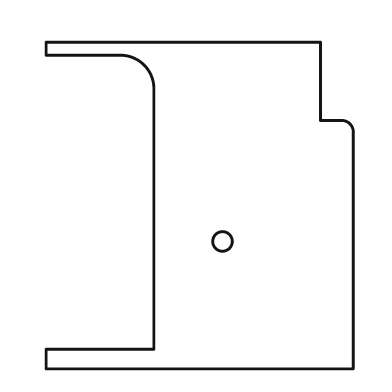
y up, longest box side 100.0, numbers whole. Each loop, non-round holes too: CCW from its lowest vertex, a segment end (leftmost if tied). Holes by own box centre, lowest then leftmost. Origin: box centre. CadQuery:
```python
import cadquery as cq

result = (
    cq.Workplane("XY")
    .moveTo(-47.0, -50.0)
    .lineTo(47.0, -50.0)
    .lineTo(47.0, 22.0)
    .threePointArc((46.0, 25.0), (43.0, 26.0))
    .lineTo(37.0, 26.0)
    .lineTo(37.0, 50.0)
    .lineTo(-47.0, 50.0)
    .lineTo(-47.0, 46.0)
    .lineTo(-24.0, 46.0)
    .threePointArc((-17.0, 43.0), (-14.0, 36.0))
    .lineTo(-14.0, -44.0)
    .lineTo(-47.0, -44.0)
    .close()
    .moveTo(7.0, -11.0)
    .circle(3.0)
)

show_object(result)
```